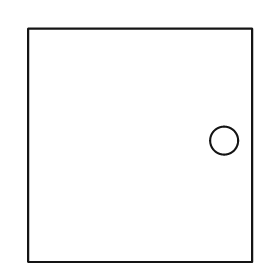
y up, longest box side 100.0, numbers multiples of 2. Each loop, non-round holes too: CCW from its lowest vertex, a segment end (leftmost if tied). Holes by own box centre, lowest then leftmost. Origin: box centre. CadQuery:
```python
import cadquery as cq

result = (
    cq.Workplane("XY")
    .moveTo(-48.0, -50.0)
    .lineTo(48.0, -50.0)
    .lineTo(48.0, 50.0)
    .lineTo(-48.0, 50.0)
    .close()
    .moveTo(36.0, 2.0)
    .circle(6.0)
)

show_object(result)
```